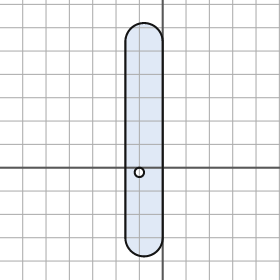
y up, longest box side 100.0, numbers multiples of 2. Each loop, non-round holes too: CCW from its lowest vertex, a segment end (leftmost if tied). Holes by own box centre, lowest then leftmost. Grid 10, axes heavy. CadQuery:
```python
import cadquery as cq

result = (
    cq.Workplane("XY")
    .moveTo(-16.0, -30.0)
    .threePointArc((-8.0, -38.0), (0.0, -30.0))
    .lineTo(0.0, 54.0)
    .threePointArc((-8.0, 62.0), (-16.0, 54.0))
    .close()
    .moveTo(-10.0, -2.0)
    .circle(2.0)
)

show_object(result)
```